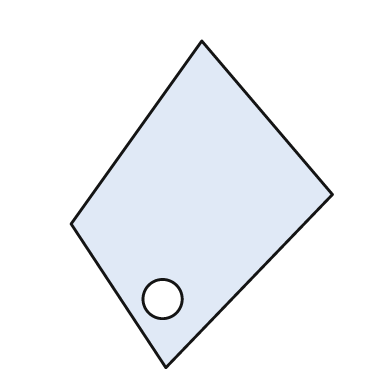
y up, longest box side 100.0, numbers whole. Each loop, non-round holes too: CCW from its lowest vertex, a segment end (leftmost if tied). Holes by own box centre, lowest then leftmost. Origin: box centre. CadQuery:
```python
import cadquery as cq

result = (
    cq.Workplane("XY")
    .moveTo(-11.0, -50.0)
    .lineTo(40.0, 3.0)
    .lineTo(0.0, 50.0)
    .lineTo(-40.0, -6.0)
    .close()
    .moveTo(-12.0, -29.0)
    .circle(6.0)
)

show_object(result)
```